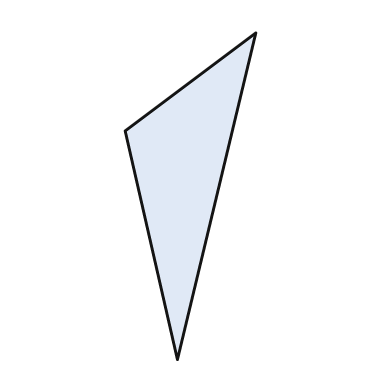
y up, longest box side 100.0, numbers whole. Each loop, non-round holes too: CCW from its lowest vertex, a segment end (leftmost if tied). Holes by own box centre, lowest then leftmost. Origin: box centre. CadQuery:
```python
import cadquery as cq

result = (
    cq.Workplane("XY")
    .moveTo(-4.0, -50.0)
    .lineTo(20.0, 50.0)
    .lineTo(-20.0, 20.0)
    .close()
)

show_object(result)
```